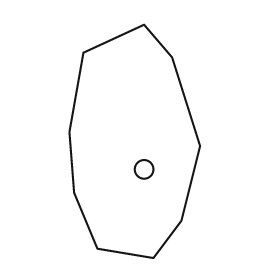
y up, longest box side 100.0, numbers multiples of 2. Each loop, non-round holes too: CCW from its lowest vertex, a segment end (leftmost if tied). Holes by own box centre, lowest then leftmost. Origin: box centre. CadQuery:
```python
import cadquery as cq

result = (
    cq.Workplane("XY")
    .moveTo(8.0, -50.0)
    .lineTo(20.0, -34.0)
    .lineTo(28.0, -2.0)
    .lineTo(16.0, 36.0)
    .lineTo(4.0, 50.0)
    .lineTo(-22.0, 38.0)
    .lineTo(-28.0, 4.0)
    .lineTo(-26.0, -22.0)
    .lineTo(-16.0, -46.0)
    .close()
    .moveTo(4.0, -12.0)
    .circle(4.0)
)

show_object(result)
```